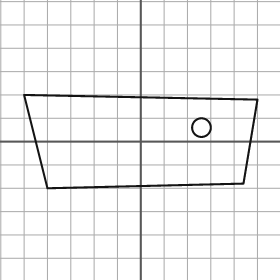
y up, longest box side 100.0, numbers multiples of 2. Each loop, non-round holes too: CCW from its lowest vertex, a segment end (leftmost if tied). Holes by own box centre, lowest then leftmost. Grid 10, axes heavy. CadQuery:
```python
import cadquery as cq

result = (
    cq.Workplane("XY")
    .moveTo(-40.0, -20.0)
    .lineTo(44.0, -18.0)
    .lineTo(50.0, 18.0)
    .lineTo(-50.0, 20.0)
    .close()
    .moveTo(26.0, 6.0)
    .circle(4.0)
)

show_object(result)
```